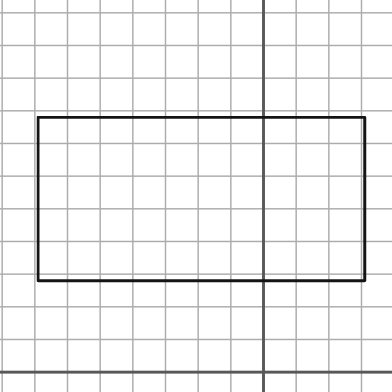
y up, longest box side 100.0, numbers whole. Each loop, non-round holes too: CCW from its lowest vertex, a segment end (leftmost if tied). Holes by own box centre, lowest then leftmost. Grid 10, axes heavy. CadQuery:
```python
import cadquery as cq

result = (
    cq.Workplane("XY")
    .moveTo(-69.0, 28.0)
    .lineTo(31.0, 28.0)
    .lineTo(31.0, 78.0)
    .lineTo(-69.0, 78.0)
    .close()
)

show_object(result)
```